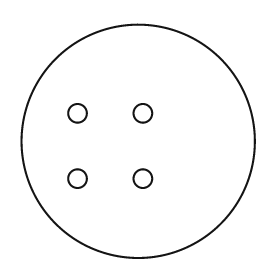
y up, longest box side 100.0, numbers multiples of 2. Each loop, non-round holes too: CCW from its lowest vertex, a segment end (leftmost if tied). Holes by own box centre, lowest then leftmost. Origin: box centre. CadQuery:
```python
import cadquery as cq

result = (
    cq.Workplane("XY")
    .moveTo(0.0, 0.0)
    .circle(50.0)
    .moveTo(-26.0, -16.0)
    .circle(4.0)
    .moveTo(2.0, -16.0)
    .circle(4.0)
    .moveTo(-26.0, 12.0)
    .circle(4.0)
    .moveTo(2.0, 12.0)
    .circle(4.0)
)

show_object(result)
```